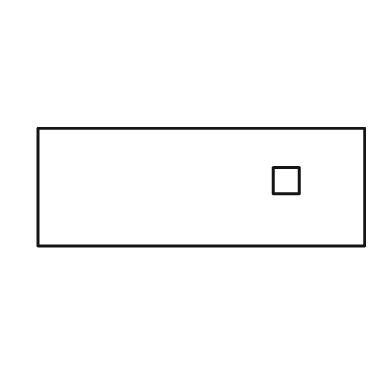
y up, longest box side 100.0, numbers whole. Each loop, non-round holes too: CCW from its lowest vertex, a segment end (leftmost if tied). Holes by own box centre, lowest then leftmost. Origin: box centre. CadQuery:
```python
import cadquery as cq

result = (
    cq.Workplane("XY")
    .moveTo(-50.0, -18.0)
    .lineTo(50.0, -18.0)
    .lineTo(50.0, 18.0)
    .lineTo(-50.0, 18.0)
    .close()
    .moveTo(22.0, -2.0)
    .lineTo(30.0, -2.0)
    .lineTo(30.0, 6.0)
    .lineTo(22.0, 6.0)
    .close()
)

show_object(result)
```